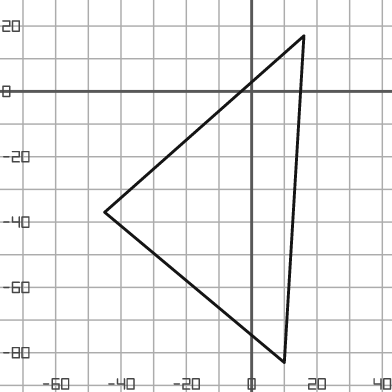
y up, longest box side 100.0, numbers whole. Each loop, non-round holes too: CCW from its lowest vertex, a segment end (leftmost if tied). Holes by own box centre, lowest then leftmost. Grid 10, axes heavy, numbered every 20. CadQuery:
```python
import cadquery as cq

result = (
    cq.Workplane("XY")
    .moveTo(10.0, -83.0)
    .lineTo(16.0, 17.0)
    .lineTo(-45.0, -37.0)
    .close()
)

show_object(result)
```